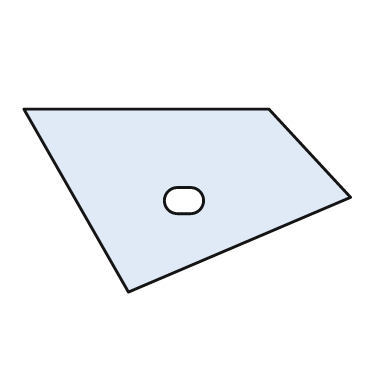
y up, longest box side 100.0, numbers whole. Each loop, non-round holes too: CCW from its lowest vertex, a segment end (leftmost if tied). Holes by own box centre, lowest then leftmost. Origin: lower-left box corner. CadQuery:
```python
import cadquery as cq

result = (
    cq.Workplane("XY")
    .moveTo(32.0, 0.0)
    .lineTo(100.0, 29.0)
    .lineTo(75.0, 56.0)
    .lineTo(0.0, 56.0)
    .close()
    .moveTo(47.0, 24.0)
    .lineTo(51.0, 24.0)
    .threePointArc((55.0, 28.0), (51.0, 32.0))
    .lineTo(47.0, 32.0)
    .threePointArc((43.0, 28.0), (47.0, 24.0))
    .close()
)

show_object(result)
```